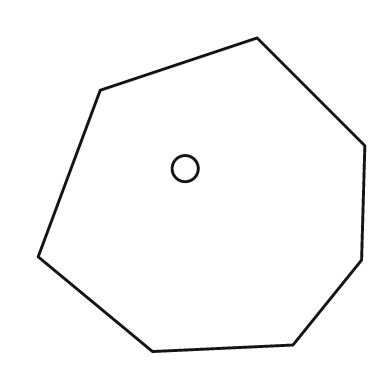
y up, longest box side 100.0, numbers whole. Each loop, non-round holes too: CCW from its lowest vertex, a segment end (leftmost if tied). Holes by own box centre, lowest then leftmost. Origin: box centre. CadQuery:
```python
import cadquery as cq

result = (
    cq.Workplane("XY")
    .moveTo(-15.0, -48.0)
    .lineTo(28.0, -46.0)
    .lineTo(49.0, -20.0)
    .lineTo(50.0, 15.0)
    .lineTo(17.0, 48.0)
    .lineTo(-31.0, 32.0)
    .lineTo(-50.0, -19.0)
    .close()
    .moveTo(-5.0, 8.0)
    .circle(4.0)
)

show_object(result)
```